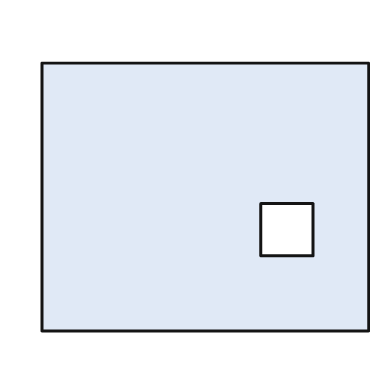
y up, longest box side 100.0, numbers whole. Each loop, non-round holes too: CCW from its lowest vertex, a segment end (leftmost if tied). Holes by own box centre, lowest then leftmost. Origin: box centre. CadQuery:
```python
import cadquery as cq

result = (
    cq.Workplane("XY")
    .moveTo(-50.0, -41.0)
    .lineTo(50.0, -41.0)
    .lineTo(50.0, 41.0)
    .lineTo(-50.0, 41.0)
    .close()
    .moveTo(17.0, -18.0)
    .lineTo(33.0, -18.0)
    .lineTo(33.0, -2.0)
    .lineTo(17.0, -2.0)
    .close()
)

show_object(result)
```